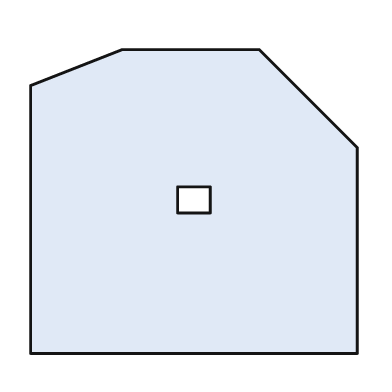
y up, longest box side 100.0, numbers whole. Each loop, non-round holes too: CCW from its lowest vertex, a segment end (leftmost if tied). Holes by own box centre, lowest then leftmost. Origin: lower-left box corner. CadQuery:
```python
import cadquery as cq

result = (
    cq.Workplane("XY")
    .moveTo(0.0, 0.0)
    .lineTo(100.0, 0.0)
    .lineTo(100.0, 63.0)
    .lineTo(70.0, 93.0)
    .lineTo(28.0, 93.0)
    .lineTo(0.0, 82.0)
    .close()
    .moveTo(45.0, 43.0)
    .lineTo(55.0, 43.0)
    .lineTo(55.0, 51.0)
    .lineTo(45.0, 51.0)
    .close()
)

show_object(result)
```